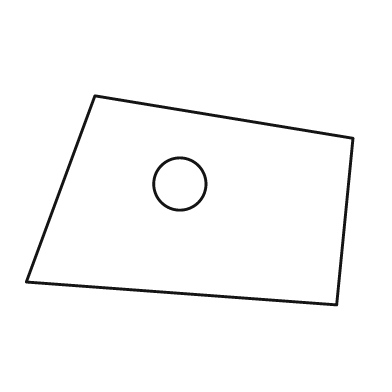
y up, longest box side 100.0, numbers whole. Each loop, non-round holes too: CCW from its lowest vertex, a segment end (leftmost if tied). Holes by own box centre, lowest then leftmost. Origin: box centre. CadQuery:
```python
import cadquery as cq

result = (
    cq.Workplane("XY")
    .moveTo(45.0, -32.0)
    .lineTo(50.0, 19.0)
    .lineTo(-29.0, 32.0)
    .lineTo(-50.0, -25.0)
    .close()
    .moveTo(-3.0, 5.0)
    .circle(8.0)
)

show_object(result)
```